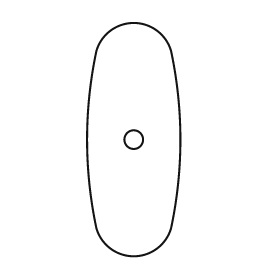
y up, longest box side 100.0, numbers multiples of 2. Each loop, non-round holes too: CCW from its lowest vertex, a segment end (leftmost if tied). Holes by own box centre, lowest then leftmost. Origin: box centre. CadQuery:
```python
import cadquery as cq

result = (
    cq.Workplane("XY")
    .moveTo(-16.0, -38.0)
    .threePointArc((0.0, -50.0), (16.0, -38.0))
    .threePointArc((20.0, 0.0), (16.0, 38.0))
    .threePointArc((0.0, 50.0), (-16.0, 38.0))
    .threePointArc((-20.0, 0.0), (-16.0, -38.0))
    .close()
    .moveTo(0.0, 0.0)
    .circle(4.0)
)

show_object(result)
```